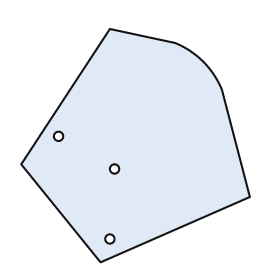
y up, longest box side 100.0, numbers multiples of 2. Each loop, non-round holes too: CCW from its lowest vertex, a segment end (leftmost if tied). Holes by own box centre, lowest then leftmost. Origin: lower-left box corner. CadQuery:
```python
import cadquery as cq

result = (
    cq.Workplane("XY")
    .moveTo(34.0, 0.0)
    .lineTo(98.0, 28.0)
    .lineTo(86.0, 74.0)
    .threePointArc((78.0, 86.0), (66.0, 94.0))
    .lineTo(38.0, 100.0)
    .lineTo(0.0, 42.0)
    .close()
    .moveTo(38.0, 10.0)
    .circle(2.0)
    .moveTo(40.0, 40.0)
    .circle(2.0)
    .moveTo(16.0, 54.0)
    .circle(2.0)
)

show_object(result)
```